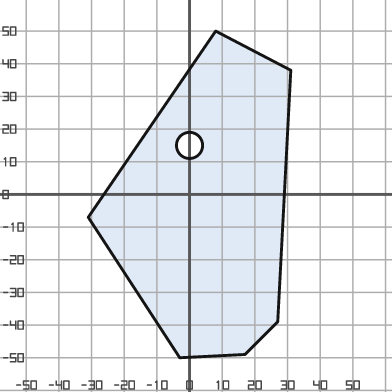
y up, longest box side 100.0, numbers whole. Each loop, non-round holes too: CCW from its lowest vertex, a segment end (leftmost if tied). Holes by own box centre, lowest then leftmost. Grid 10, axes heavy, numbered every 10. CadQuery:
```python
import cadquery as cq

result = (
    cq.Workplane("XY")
    .moveTo(-3.0, -50.0)
    .lineTo(17.0, -49.0)
    .lineTo(27.0, -39.0)
    .lineTo(31.0, 38.0)
    .lineTo(8.0, 50.0)
    .lineTo(-31.0, -7.0)
    .close()
    .moveTo(0.0, 15.0)
    .circle(4.0)
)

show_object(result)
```